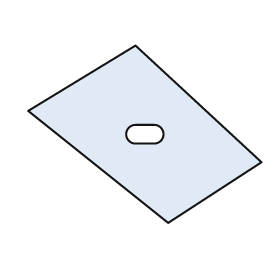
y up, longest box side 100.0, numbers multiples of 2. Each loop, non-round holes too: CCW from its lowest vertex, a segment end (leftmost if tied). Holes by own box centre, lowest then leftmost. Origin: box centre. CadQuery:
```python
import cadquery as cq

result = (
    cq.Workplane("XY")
    .moveTo(10.0, -38.0)
    .lineTo(50.0, -12.0)
    .lineTo(-4.0, 38.0)
    .lineTo(-50.0, 10.0)
    .close()
    .moveTo(-4.0, -4.0)
    .lineTo(4.0, -4.0)
    .threePointArc((8.0, 0.0), (4.0, 4.0))
    .lineTo(-4.0, 4.0)
    .threePointArc((-8.0, 0.0), (-4.0, -4.0))
    .close()
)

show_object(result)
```